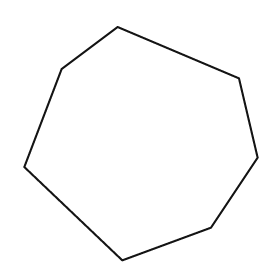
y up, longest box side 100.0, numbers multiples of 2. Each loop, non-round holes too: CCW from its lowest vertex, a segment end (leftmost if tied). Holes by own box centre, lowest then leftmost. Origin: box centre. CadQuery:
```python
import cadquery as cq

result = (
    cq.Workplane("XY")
    .moveTo(-8.0, -50.0)
    .lineTo(30.0, -36.0)
    .lineTo(50.0, -6.0)
    .lineTo(42.0, 28.0)
    .lineTo(-10.0, 50.0)
    .lineTo(-34.0, 32.0)
    .lineTo(-50.0, -10.0)
    .close()
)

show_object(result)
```